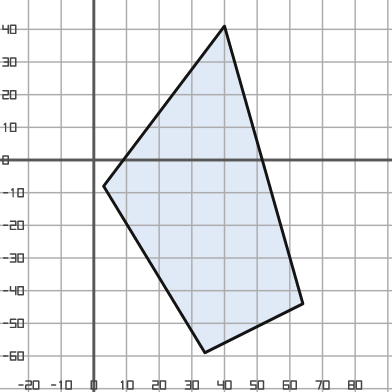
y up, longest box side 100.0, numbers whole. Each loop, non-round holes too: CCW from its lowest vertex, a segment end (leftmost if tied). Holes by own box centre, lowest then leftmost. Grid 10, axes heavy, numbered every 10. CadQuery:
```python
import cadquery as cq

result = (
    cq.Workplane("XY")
    .moveTo(34.0, -59.0)
    .lineTo(64.0, -44.0)
    .lineTo(40.0, 41.0)
    .lineTo(3.0, -8.0)
    .close()
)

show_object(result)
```